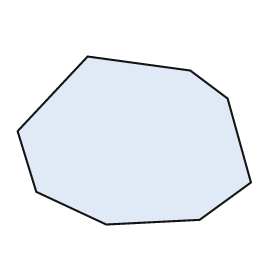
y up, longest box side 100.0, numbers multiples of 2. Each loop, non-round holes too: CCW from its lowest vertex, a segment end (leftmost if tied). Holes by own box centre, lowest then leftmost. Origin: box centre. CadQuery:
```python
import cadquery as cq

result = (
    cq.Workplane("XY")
    .moveTo(-12.0, -36.0)
    .lineTo(28.0, -34.0)
    .lineTo(50.0, -18.0)
    .lineTo(40.0, 18.0)
    .lineTo(24.0, 30.0)
    .lineTo(-20.0, 36.0)
    .lineTo(-50.0, 4.0)
    .lineTo(-42.0, -22.0)
    .close()
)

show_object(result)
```